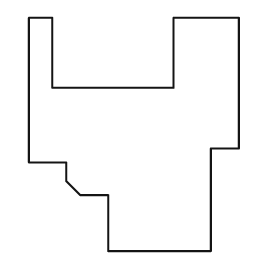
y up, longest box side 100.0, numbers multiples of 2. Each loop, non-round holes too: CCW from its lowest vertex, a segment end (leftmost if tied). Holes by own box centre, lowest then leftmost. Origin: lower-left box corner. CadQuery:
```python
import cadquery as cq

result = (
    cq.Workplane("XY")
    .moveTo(34.0, 0.0)
    .lineTo(78.0, 0.0)
    .lineTo(78.0, 44.0)
    .lineTo(90.0, 44.0)
    .lineTo(90.0, 100.0)
    .lineTo(62.0, 100.0)
    .lineTo(62.0, 70.0)
    .lineTo(10.0, 70.0)
    .lineTo(10.0, 100.0)
    .lineTo(0.0, 100.0)
    .lineTo(0.0, 38.0)
    .lineTo(16.0, 38.0)
    .lineTo(16.0, 30.0)
    .lineTo(22.0, 24.0)
    .lineTo(34.0, 24.0)
    .close()
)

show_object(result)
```